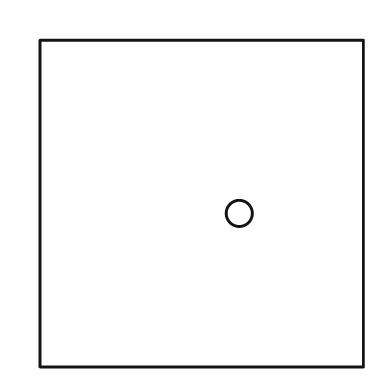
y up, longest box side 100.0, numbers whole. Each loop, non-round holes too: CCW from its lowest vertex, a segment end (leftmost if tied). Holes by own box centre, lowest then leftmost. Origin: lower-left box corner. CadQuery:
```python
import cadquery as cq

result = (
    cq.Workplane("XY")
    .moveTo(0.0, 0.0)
    .lineTo(99.0, 0.0)
    .lineTo(99.0, 100.0)
    .lineTo(0.0, 100.0)
    .close()
    .moveTo(61.0, 47.0)
    .circle(4.0)
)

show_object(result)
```